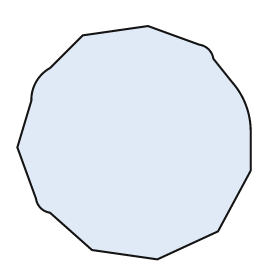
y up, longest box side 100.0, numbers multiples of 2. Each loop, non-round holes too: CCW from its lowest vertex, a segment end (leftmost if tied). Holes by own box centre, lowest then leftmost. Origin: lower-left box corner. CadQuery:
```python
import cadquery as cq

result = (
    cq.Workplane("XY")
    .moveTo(60.0, 0.0)
    .lineTo(86.0, 12.0)
    .lineTo(100.0, 38.0)
    .lineTo(100.0, 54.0)
    .threePointArc((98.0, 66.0), (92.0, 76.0))
    .lineTo(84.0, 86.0)
    .threePointArc((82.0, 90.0), (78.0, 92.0))
    .lineTo(56.0, 100.0)
    .lineTo(28.0, 96.0)
    .lineTo(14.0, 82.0)
    .threePointArc((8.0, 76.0), (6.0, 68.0))
    .lineTo(0.0, 48.0)
    .lineTo(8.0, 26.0)
    .threePointArc((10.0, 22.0), (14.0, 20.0))
    .lineTo(32.0, 4.0)
    .close()
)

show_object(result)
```